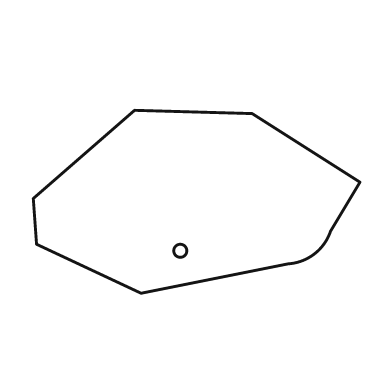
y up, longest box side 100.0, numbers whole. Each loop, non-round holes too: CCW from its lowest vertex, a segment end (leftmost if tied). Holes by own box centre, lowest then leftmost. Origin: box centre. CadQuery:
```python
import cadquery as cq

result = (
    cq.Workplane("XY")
    .moveTo(-17.0, -28.0)
    .lineTo(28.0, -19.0)
    .threePointArc((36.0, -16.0), (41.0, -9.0))
    .lineTo(50.0, 6.0)
    .lineTo(17.0, 27.0)
    .lineTo(-19.0, 28.0)
    .lineTo(-50.0, 1.0)
    .lineTo(-49.0, -13.0)
    .close()
    .moveTo(-5.0, -15.0)
    .circle(2.0)
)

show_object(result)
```